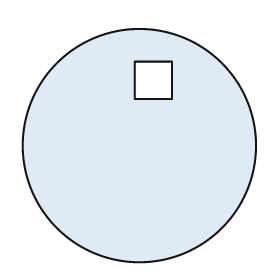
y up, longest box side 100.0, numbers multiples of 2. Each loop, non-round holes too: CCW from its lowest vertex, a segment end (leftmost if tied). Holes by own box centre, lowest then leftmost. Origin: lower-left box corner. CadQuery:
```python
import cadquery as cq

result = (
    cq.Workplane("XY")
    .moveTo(50.0, 50.0)
    .circle(50.0)
    .moveTo(48.0, 70.0)
    .lineTo(64.0, 70.0)
    .lineTo(64.0, 86.0)
    .lineTo(48.0, 86.0)
    .close()
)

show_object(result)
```